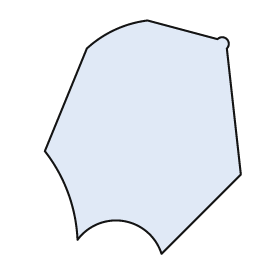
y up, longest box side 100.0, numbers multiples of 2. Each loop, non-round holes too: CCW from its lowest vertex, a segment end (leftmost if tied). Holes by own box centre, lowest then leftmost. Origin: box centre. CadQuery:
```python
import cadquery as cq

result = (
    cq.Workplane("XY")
    .moveTo(8.0, -50.0)
    .lineTo(42.0, -16.0)
    .lineTo(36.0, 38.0)
    .threePointArc((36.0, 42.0), (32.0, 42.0))
    .lineTo(2.0, 50.0)
    .threePointArc((-12.0, 46.0), (-24.0, 38.0))
    .lineTo(-42.0, -6.0)
    .threePointArc((-32.0, -24.0), (-28.0, -44.0))
    .threePointArc((-8.0, -36.0), (8.0, -50.0))
    .close()
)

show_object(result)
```